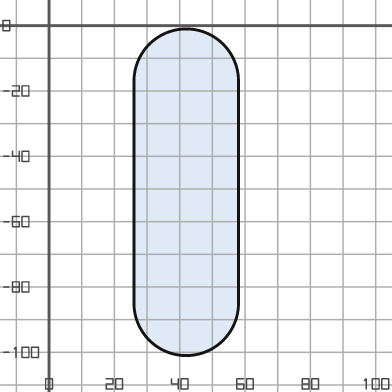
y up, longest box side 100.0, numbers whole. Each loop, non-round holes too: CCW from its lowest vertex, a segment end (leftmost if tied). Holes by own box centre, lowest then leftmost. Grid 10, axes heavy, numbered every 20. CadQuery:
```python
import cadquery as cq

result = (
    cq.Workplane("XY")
    .moveTo(26.0, -85.0)
    .threePointArc((42.0, -101.0), (58.0, -85.0))
    .lineTo(58.0, -17.0)
    .threePointArc((42.0, -1.0), (26.0, -17.0))
    .close()
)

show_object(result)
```